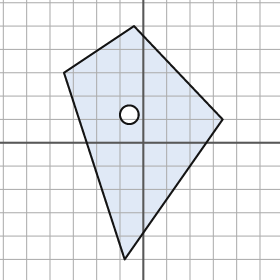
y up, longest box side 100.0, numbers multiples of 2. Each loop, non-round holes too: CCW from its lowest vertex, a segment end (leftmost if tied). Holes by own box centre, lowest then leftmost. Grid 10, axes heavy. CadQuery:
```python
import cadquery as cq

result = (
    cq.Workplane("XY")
    .moveTo(-8.0, -50.0)
    .lineTo(34.0, 10.0)
    .lineTo(-4.0, 50.0)
    .lineTo(-34.0, 30.0)
    .close()
    .moveTo(-6.0, 12.0)
    .circle(4.0)
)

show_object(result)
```